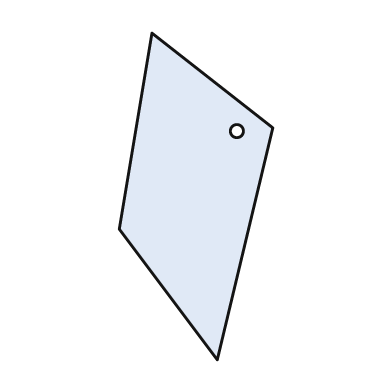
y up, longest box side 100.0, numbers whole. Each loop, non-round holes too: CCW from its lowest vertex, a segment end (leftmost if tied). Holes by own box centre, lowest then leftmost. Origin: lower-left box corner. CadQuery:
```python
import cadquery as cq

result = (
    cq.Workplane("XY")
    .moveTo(30.0, 0.0)
    .lineTo(47.0, 71.0)
    .lineTo(10.0, 100.0)
    .lineTo(0.0, 40.0)
    .close()
    .moveTo(36.0, 70.0)
    .circle(2.0)
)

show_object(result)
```